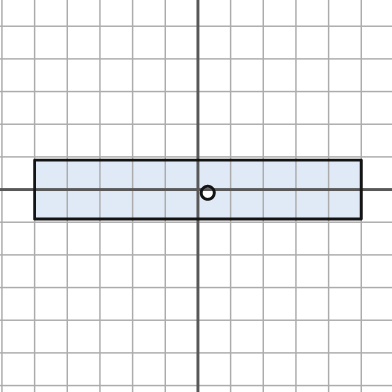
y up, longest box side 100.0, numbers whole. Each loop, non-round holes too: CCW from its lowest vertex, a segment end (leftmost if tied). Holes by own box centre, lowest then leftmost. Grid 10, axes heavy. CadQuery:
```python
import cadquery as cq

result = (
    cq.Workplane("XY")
    .moveTo(-50.0, -9.0)
    .lineTo(50.0, -9.0)
    .lineTo(50.0, 9.0)
    .lineTo(-50.0, 9.0)
    .close()
    .moveTo(3.0, -1.0)
    .circle(2.0)
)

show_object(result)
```